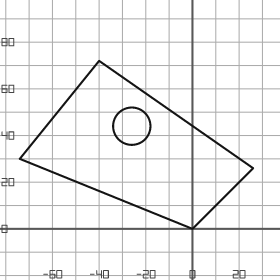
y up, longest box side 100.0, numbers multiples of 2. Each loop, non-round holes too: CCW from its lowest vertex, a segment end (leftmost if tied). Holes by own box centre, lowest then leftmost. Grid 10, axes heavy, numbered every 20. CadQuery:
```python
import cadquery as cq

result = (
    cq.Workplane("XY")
    .moveTo(0.0, 0.0)
    .lineTo(26.0, 26.0)
    .lineTo(-40.0, 72.0)
    .lineTo(-74.0, 30.0)
    .close()
    .moveTo(-26.0, 44.0)
    .circle(8.0)
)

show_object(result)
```